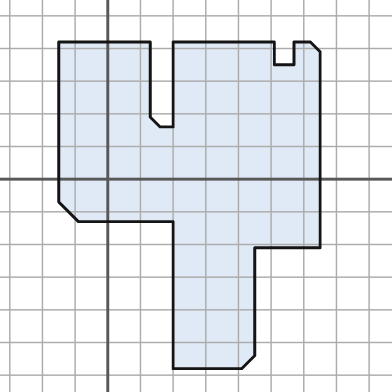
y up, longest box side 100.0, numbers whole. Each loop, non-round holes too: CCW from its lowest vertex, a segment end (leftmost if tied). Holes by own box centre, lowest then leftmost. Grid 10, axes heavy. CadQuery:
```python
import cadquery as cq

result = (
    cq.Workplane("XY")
    .moveTo(20.0, -58.0)
    .lineTo(41.0, -58.0)
    .lineTo(45.0, -54.0)
    .lineTo(45.0, -21.0)
    .lineTo(65.0, -21.0)
    .lineTo(65.0, 39.0)
    .lineTo(62.0, 42.0)
    .lineTo(57.0, 42.0)
    .lineTo(57.0, 35.0)
    .lineTo(51.0, 35.0)
    .lineTo(51.0, 42.0)
    .lineTo(20.0, 42.0)
    .lineTo(20.0, 16.0)
    .lineTo(16.0, 16.0)
    .lineTo(13.0, 19.0)
    .lineTo(13.0, 42.0)
    .lineTo(-15.0, 42.0)
    .lineTo(-15.0, -7.0)
    .lineTo(-9.0, -13.0)
    .lineTo(20.0, -13.0)
    .close()
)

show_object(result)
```